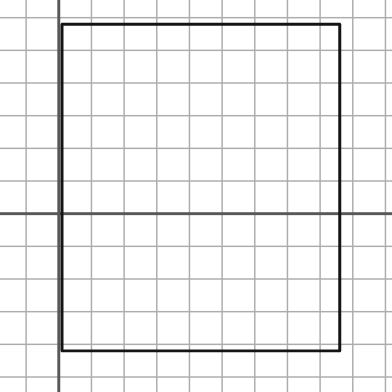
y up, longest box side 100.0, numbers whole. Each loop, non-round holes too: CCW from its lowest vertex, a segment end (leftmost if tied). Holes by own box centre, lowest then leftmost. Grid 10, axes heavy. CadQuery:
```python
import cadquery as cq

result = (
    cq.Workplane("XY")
    .moveTo(1.0, -42.0)
    .lineTo(86.0, -42.0)
    .lineTo(86.0, 58.0)
    .lineTo(1.0, 58.0)
    .close()
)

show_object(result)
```